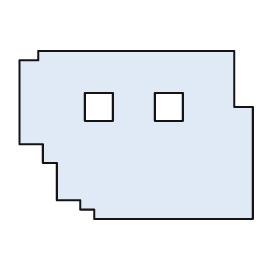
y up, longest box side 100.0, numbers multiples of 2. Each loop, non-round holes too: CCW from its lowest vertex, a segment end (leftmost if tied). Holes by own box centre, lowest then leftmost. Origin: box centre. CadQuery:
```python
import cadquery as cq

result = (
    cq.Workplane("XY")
    .moveTo(-18.0, -36.0)
    .lineTo(50.0, -36.0)
    .lineTo(50.0, 12.0)
    .lineTo(42.0, 12.0)
    .lineTo(42.0, 36.0)
    .lineTo(-42.0, 36.0)
    .lineTo(-42.0, 32.0)
    .lineTo(-50.0, 32.0)
    .lineTo(-50.0, -4.0)
    .lineTo(-40.0, -4.0)
    .lineTo(-40.0, -12.0)
    .lineTo(-34.0, -12.0)
    .lineTo(-34.0, -28.0)
    .lineTo(-24.0, -28.0)
    .lineTo(-24.0, -32.0)
    .lineTo(-18.0, -32.0)
    .close()
    .moveTo(-22.0, 6.0)
    .lineTo(-10.0, 6.0)
    .lineTo(-10.0, 18.0)
    .lineTo(-22.0, 18.0)
    .close()
    .moveTo(8.0, 6.0)
    .lineTo(20.0, 6.0)
    .lineTo(20.0, 18.0)
    .lineTo(8.0, 18.0)
    .close()
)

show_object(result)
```